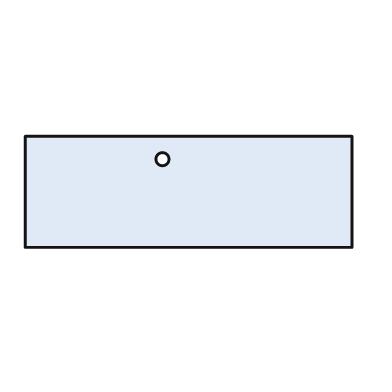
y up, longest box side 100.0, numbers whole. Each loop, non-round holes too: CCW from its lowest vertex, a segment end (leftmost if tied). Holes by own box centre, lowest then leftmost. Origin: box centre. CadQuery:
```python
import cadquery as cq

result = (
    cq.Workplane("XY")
    .moveTo(-50.0, -17.0)
    .lineTo(50.0, -17.0)
    .lineTo(50.0, 17.0)
    .lineTo(-50.0, 17.0)
    .close()
    .moveTo(-8.0, 10.0)
    .circle(2.0)
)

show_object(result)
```